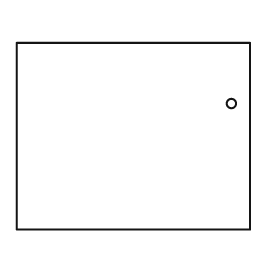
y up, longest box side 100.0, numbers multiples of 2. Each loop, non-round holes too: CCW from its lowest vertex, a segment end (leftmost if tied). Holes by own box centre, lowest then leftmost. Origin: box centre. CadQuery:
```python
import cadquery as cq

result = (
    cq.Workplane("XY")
    .moveTo(-50.0, -40.0)
    .lineTo(50.0, -40.0)
    .lineTo(50.0, 40.0)
    .lineTo(-50.0, 40.0)
    .close()
    .moveTo(42.0, 14.0)
    .circle(2.0)
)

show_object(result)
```